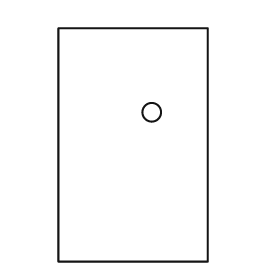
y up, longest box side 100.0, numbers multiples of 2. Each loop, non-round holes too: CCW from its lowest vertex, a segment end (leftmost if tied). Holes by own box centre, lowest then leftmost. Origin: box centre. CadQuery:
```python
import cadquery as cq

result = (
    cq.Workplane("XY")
    .moveTo(-32.0, -50.0)
    .lineTo(32.0, -50.0)
    .lineTo(32.0, 50.0)
    .lineTo(-32.0, 50.0)
    .close()
    .moveTo(8.0, 14.0)
    .circle(4.0)
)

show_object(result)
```